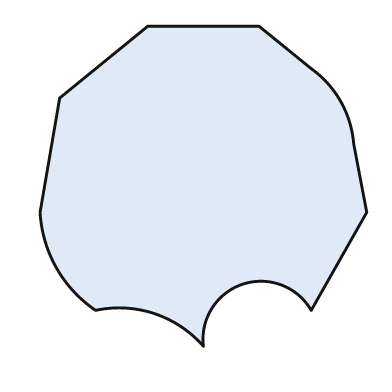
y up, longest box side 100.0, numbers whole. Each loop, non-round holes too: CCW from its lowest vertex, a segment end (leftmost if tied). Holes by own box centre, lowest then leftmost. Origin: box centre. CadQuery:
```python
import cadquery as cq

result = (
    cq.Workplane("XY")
    .moveTo(0.0, -49.0)
    .threePointArc((12.0, -30.0), (33.0, -38.0))
    .lineTo(50.0, -8.0)
    .lineTo(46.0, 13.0)
    .threePointArc((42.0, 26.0), (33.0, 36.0))
    .lineTo(17.0, 49.0)
    .lineTo(-17.0, 49.0)
    .lineTo(-44.0, 27.0)
    .lineTo(-50.0, -8.0)
    .threePointArc((-45.0, -25.0), (-33.0, -38.0))
    .threePointArc((-15.0, -39.0), (0.0, -49.0))
    .close()
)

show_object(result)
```